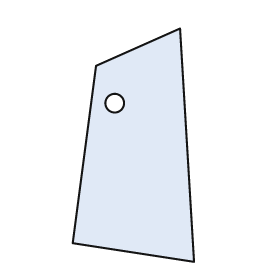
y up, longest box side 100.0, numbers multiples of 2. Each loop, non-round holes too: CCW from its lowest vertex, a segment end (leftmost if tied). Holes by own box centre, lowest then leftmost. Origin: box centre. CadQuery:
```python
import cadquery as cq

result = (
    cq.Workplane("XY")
    .moveTo(26.0, -50.0)
    .lineTo(20.0, 50.0)
    .lineTo(-16.0, 34.0)
    .lineTo(-26.0, -42.0)
    .close()
    .moveTo(-8.0, 18.0)
    .circle(4.0)
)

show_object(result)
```